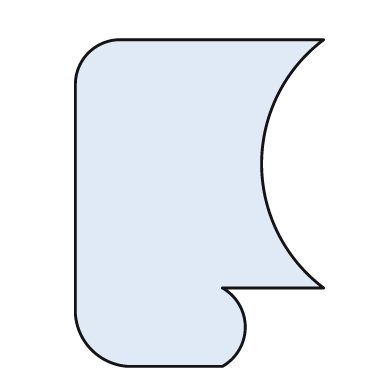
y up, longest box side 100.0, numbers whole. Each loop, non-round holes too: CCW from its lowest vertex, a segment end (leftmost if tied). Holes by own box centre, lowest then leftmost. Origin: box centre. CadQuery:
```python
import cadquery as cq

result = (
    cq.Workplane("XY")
    .moveTo(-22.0, -50.0)
    .lineTo(7.0, -50.0)
    .threePointArc((14.0, -38.0), (7.0, -26.0))
    .lineTo(38.0, -26.0)
    .threePointArc((19.0, 12.0), (38.0, 50.0))
    .lineTo(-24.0, 50.0)
    .threePointArc((-34.0, 46.0), (-38.0, 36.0))
    .lineTo(-38.0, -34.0)
    .threePointArc((-33.0, -45.0), (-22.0, -50.0))
    .close()
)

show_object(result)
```